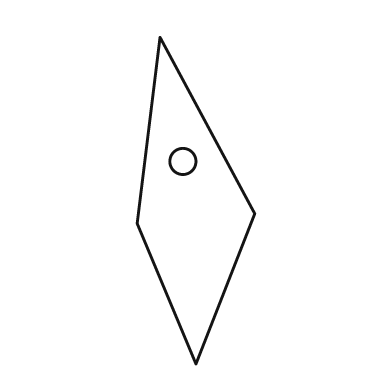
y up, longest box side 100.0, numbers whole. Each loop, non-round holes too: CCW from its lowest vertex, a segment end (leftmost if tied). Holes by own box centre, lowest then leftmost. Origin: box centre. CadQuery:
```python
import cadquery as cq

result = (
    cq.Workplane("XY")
    .moveTo(0.0, -50.0)
    .lineTo(18.0, -4.0)
    .lineTo(-11.0, 50.0)
    .lineTo(-18.0, -7.0)
    .close()
    .moveTo(-4.0, 12.0)
    .circle(4.0)
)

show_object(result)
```